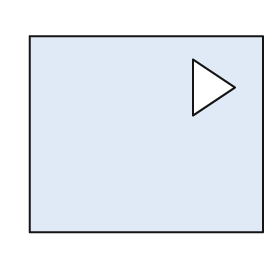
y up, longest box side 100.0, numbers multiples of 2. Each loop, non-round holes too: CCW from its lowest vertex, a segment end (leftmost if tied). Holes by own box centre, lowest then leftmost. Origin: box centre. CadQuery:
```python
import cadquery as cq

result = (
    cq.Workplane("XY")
    .moveTo(-50.0, -42.0)
    .lineTo(50.0, -42.0)
    .lineTo(50.0, 42.0)
    .lineTo(-50.0, 42.0)
    .close()
    .moveTo(20.0, 8.0)
    .lineTo(38.0, 20.0)
    .lineTo(20.0, 32.0)
    .close()
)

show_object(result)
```